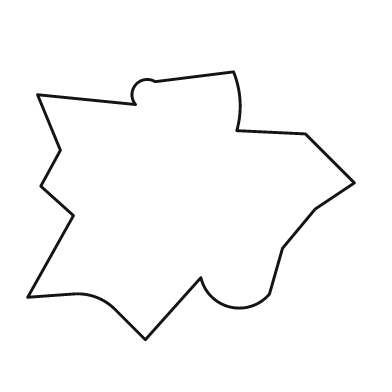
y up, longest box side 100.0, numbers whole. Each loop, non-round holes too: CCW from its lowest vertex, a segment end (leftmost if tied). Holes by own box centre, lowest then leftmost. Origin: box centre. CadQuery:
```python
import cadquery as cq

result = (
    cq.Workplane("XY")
    .moveTo(-14.0, -41.0)
    .lineTo(3.0, -22.0)
    .threePointArc((12.0, -31.0), (24.0, -27.0))
    .lineTo(28.0, -13.0)
    .lineTo(38.0, -1.0)
    .lineTo(50.0, 7.0)
    .lineTo(35.0, 22.0)
    .lineTo(14.0, 23.0)
    .threePointArc((15.0, 32.0), (13.0, 41.0))
    .lineTo(-11.0, 38.0)
    .threePointArc((-17.0, 37.0), (-17.0, 31.0))
    .lineTo(-47.0, 34.0)
    .lineTo(-40.0, 17.0)
    .lineTo(-46.0, 6.0)
    .lineTo(-36.0, -3.0)
    .lineTo(-50.0, -28.0)
    .lineTo(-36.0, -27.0)
    .threePointArc((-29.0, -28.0), (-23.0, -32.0))
    .close()
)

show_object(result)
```